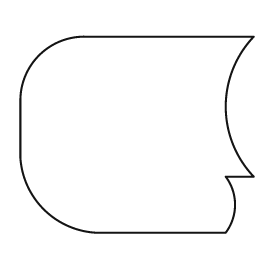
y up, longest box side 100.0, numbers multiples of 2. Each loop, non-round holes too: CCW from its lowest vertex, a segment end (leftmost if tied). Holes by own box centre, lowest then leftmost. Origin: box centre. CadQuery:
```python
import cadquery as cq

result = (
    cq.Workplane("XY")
    .moveTo(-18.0, -42.0)
    .lineTo(38.0, -42.0)
    .threePointArc((42.0, -30.0), (38.0, -18.0))
    .lineTo(50.0, -18.0)
    .threePointArc((38.0, 12.0), (50.0, 42.0))
    .lineTo(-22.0, 42.0)
    .threePointArc((-42.0, 34.0), (-50.0, 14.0))
    .lineTo(-50.0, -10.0)
    .threePointArc((-40.0, -32.0), (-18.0, -42.0))
    .close()
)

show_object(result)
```